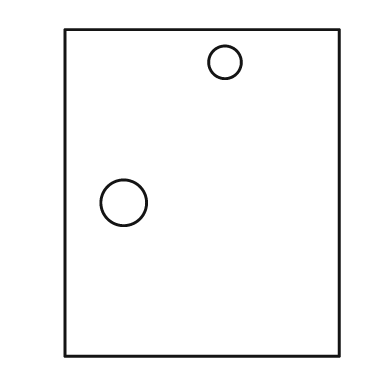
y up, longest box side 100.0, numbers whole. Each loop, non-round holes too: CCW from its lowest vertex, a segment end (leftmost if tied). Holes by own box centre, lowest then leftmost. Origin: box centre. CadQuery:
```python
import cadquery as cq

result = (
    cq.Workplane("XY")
    .moveTo(-42.0, -50.0)
    .lineTo(42.0, -50.0)
    .lineTo(42.0, 50.0)
    .lineTo(-42.0, 50.0)
    .close()
    .moveTo(-24.0, -3.0)
    .circle(7.0)
    .moveTo(7.0, 40.0)
    .circle(5.0)
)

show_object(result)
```